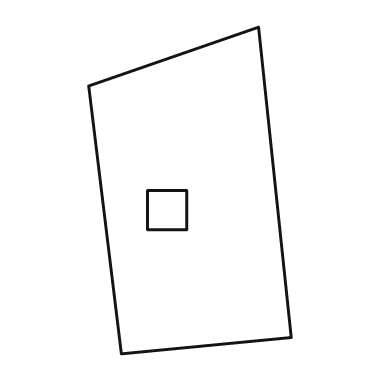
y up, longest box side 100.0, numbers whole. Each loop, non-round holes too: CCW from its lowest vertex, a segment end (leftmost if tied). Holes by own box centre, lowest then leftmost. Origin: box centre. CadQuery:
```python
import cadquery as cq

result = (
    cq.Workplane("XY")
    .moveTo(-21.0, -50.0)
    .lineTo(31.0, -45.0)
    .lineTo(21.0, 50.0)
    .lineTo(-31.0, 32.0)
    .close()
    .moveTo(-13.0, -12.0)
    .lineTo(-1.0, -12.0)
    .lineTo(-1.0, 0.0)
    .lineTo(-13.0, 0.0)
    .close()
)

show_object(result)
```